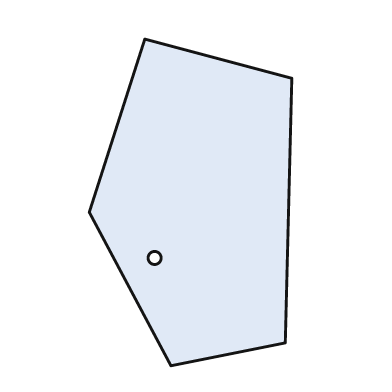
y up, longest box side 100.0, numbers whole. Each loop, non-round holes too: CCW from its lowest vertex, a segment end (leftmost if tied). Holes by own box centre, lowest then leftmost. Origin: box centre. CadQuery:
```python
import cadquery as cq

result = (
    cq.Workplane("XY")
    .moveTo(-6.0, -50.0)
    .lineTo(29.0, -43.0)
    .lineTo(31.0, 38.0)
    .lineTo(-14.0, 50.0)
    .lineTo(-31.0, -3.0)
    .close()
    .moveTo(-11.0, -17.0)
    .circle(2.0)
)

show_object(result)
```